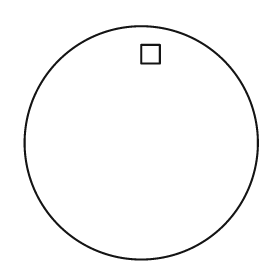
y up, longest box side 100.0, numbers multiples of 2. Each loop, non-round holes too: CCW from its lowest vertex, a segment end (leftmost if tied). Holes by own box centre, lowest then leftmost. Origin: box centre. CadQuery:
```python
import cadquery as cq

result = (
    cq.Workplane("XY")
    .moveTo(0.0, 0.0)
    .circle(50.0)
    .moveTo(0.0, 34.0)
    .lineTo(8.0, 34.0)
    .lineTo(8.0, 42.0)
    .lineTo(0.0, 42.0)
    .close()
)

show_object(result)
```